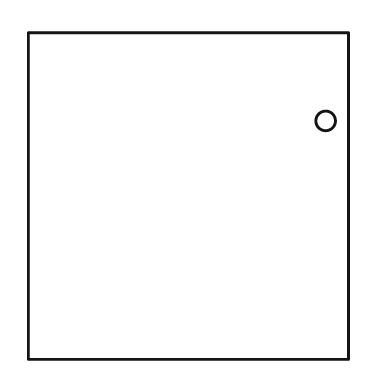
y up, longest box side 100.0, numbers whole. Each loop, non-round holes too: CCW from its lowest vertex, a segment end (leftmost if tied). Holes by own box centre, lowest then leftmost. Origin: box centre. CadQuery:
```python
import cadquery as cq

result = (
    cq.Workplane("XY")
    .moveTo(-49.0, -50.0)
    .lineTo(49.0, -50.0)
    .lineTo(49.0, 50.0)
    .lineTo(-49.0, 50.0)
    .close()
    .moveTo(42.0, 23.0)
    .circle(3.0)
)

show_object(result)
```